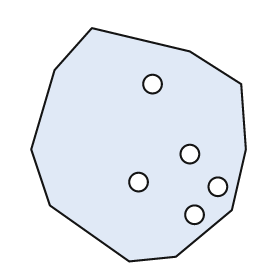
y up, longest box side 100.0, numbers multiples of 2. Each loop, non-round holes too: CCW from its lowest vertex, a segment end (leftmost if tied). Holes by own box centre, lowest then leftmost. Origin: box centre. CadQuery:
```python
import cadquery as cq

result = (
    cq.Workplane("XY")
    .moveTo(-4.0, -50.0)
    .lineTo(16.0, -48.0)
    .lineTo(40.0, -28.0)
    .lineTo(46.0, -2.0)
    .lineTo(44.0, 26.0)
    .lineTo(22.0, 40.0)
    .lineTo(-20.0, 50.0)
    .lineTo(-36.0, 32.0)
    .lineTo(-46.0, -2.0)
    .lineTo(-38.0, -26.0)
    .close()
    .moveTo(24.0, -30.0)
    .circle(4.0)
    .moveTo(34.0, -18.0)
    .circle(4.0)
    .moveTo(0.0, -16.0)
    .circle(4.0)
    .moveTo(22.0, -4.0)
    .circle(4.0)
    .moveTo(6.0, 26.0)
    .circle(4.0)
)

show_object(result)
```